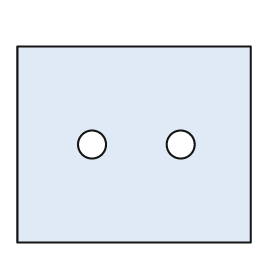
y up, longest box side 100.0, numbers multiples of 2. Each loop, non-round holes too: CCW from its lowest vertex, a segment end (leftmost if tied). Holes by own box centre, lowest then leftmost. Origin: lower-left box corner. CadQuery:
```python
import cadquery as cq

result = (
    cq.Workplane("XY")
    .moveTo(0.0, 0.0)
    .lineTo(100.0, 0.0)
    .lineTo(100.0, 84.0)
    .lineTo(0.0, 84.0)
    .close()
    .moveTo(32.0, 42.0)
    .circle(6.0)
    .moveTo(70.0, 42.0)
    .circle(6.0)
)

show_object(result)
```